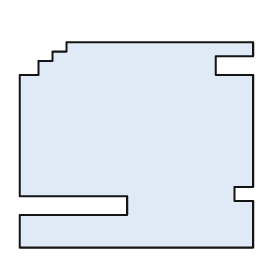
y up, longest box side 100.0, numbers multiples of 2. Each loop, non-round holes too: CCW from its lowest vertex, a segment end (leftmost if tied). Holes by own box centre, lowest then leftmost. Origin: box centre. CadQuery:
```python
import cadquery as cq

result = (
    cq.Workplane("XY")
    .moveTo(-50.0, -44.0)
    .lineTo(50.0, -44.0)
    .lineTo(50.0, -24.0)
    .lineTo(42.0, -24.0)
    .lineTo(42.0, -18.0)
    .lineTo(50.0, -18.0)
    .lineTo(50.0, 30.0)
    .lineTo(34.0, 30.0)
    .lineTo(34.0, 38.0)
    .lineTo(50.0, 38.0)
    .lineTo(50.0, 44.0)
    .lineTo(-30.0, 44.0)
    .lineTo(-30.0, 40.0)
    .lineTo(-36.0, 40.0)
    .lineTo(-36.0, 36.0)
    .lineTo(-42.0, 36.0)
    .lineTo(-42.0, 30.0)
    .lineTo(-50.0, 30.0)
    .lineTo(-50.0, -22.0)
    .lineTo(-4.0, -22.0)
    .lineTo(-4.0, -30.0)
    .lineTo(-50.0, -30.0)
    .close()
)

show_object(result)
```